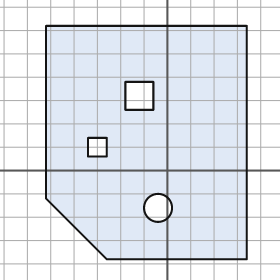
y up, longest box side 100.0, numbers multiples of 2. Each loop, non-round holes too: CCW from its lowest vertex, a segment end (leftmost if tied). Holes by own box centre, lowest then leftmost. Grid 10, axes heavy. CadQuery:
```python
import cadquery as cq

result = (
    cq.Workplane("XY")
    .moveTo(-26.0, -38.0)
    .lineTo(34.0, -38.0)
    .lineTo(34.0, 62.0)
    .lineTo(-52.0, 62.0)
    .lineTo(-52.0, -12.0)
    .close()
    .moveTo(-4.0, -16.0)
    .circle(6.0)
    .moveTo(-34.0, 6.0)
    .lineTo(-26.0, 6.0)
    .lineTo(-26.0, 14.0)
    .lineTo(-34.0, 14.0)
    .close()
    .moveTo(-18.0, 26.0)
    .lineTo(-6.0, 26.0)
    .lineTo(-6.0, 38.0)
    .lineTo(-18.0, 38.0)
    .close()
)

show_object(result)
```